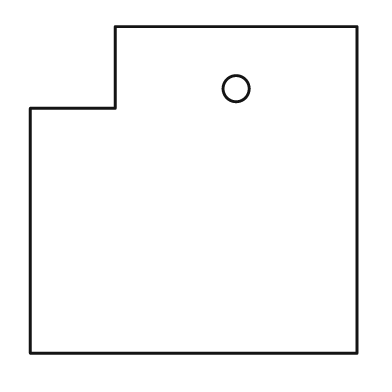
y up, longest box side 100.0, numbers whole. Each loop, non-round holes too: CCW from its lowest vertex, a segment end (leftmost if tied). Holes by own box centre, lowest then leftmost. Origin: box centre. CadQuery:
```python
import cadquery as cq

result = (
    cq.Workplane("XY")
    .moveTo(-50.0, -50.0)
    .lineTo(50.0, -50.0)
    .lineTo(50.0, 50.0)
    .lineTo(-24.0, 50.0)
    .lineTo(-24.0, 25.0)
    .lineTo(-50.0, 25.0)
    .close()
    .moveTo(13.0, 31.0)
    .circle(4.0)
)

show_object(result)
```